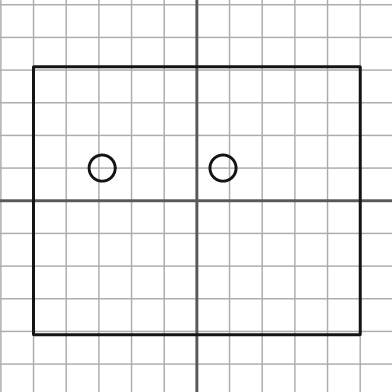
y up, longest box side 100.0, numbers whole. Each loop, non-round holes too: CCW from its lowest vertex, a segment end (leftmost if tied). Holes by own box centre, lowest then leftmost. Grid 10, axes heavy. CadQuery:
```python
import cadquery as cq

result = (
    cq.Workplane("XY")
    .moveTo(-50.0, -41.0)
    .lineTo(50.0, -41.0)
    .lineTo(50.0, 41.0)
    .lineTo(-50.0, 41.0)
    .close()
    .moveTo(-29.0, 10.0)
    .circle(4.0)
    .moveTo(8.0, 10.0)
    .circle(4.0)
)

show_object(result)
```